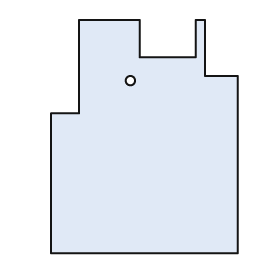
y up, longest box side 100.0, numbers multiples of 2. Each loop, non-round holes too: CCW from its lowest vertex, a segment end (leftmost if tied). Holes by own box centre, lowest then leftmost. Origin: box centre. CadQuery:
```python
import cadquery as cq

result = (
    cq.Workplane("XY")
    .moveTo(-40.0, -50.0)
    .lineTo(40.0, -50.0)
    .lineTo(40.0, 26.0)
    .lineTo(26.0, 26.0)
    .lineTo(26.0, 50.0)
    .lineTo(22.0, 50.0)
    .lineTo(22.0, 34.0)
    .lineTo(-2.0, 34.0)
    .lineTo(-2.0, 50.0)
    .lineTo(-28.0, 50.0)
    .lineTo(-28.0, 10.0)
    .lineTo(-40.0, 10.0)
    .close()
    .moveTo(-6.0, 24.0)
    .circle(2.0)
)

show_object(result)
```